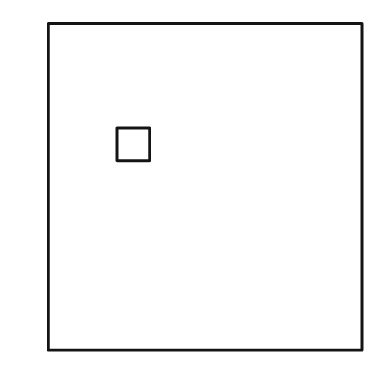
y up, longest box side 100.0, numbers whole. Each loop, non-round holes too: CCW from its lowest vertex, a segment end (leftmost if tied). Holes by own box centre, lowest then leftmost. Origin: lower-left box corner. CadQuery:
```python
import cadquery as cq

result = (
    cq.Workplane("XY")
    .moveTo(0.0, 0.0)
    .lineTo(96.0, 0.0)
    .lineTo(96.0, 100.0)
    .lineTo(0.0, 100.0)
    .close()
    .moveTo(21.0, 58.0)
    .lineTo(31.0, 58.0)
    .lineTo(31.0, 68.0)
    .lineTo(21.0, 68.0)
    .close()
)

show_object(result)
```